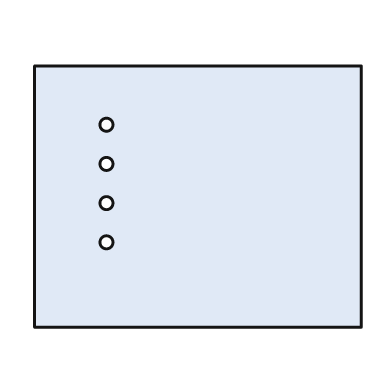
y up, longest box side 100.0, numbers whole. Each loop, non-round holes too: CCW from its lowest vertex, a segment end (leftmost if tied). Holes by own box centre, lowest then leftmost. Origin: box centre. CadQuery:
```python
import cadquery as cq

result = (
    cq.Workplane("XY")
    .moveTo(-50.0, -40.0)
    .lineTo(50.0, -40.0)
    .lineTo(50.0, 40.0)
    .lineTo(-50.0, 40.0)
    .close()
    .moveTo(-28.0, -14.0)
    .circle(2.0)
    .moveTo(-28.0, -2.0)
    .circle(2.0)
    .moveTo(-28.0, 10.0)
    .circle(2.0)
    .moveTo(-28.0, 22.0)
    .circle(2.0)
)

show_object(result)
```